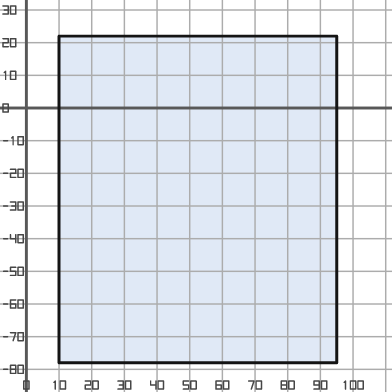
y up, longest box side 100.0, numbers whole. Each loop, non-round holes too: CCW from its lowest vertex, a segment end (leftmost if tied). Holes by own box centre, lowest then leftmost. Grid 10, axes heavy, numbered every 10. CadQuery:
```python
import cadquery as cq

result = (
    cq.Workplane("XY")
    .moveTo(10.0, -78.0)
    .lineTo(95.0, -78.0)
    .lineTo(95.0, 22.0)
    .lineTo(10.0, 22.0)
    .close()
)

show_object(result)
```